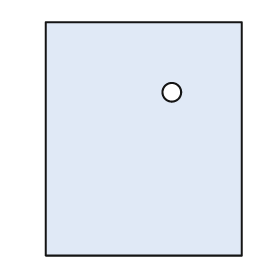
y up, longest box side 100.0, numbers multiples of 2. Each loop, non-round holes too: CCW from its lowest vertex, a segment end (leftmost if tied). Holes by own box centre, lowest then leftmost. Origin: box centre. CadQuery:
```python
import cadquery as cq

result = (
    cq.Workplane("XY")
    .moveTo(-42.0, -50.0)
    .lineTo(42.0, -50.0)
    .lineTo(42.0, 50.0)
    .lineTo(-42.0, 50.0)
    .close()
    .moveTo(12.0, 20.0)
    .circle(4.0)
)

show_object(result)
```